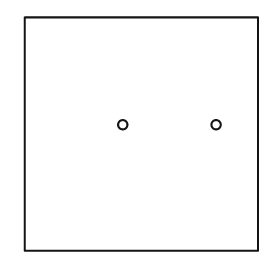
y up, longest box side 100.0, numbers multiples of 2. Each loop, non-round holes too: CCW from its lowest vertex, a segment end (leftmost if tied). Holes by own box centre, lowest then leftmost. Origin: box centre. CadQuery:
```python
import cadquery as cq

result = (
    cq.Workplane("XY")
    .moveTo(-50.0, -50.0)
    .lineTo(50.0, -50.0)
    .lineTo(50.0, 50.0)
    .lineTo(-50.0, 50.0)
    .close()
    .moveTo(-8.0, 4.0)
    .circle(2.0)
    .moveTo(32.0, 4.0)
    .circle(2.0)
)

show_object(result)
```